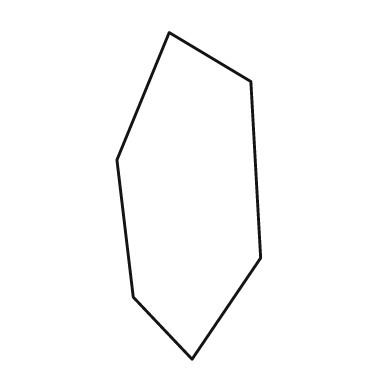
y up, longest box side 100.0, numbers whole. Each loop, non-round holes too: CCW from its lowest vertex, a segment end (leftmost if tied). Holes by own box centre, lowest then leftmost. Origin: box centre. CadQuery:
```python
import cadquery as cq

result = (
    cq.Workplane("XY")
    .moveTo(1.0, -50.0)
    .lineTo(22.0, -19.0)
    .lineTo(19.0, 35.0)
    .lineTo(-6.0, 50.0)
    .lineTo(-22.0, 11.0)
    .lineTo(-17.0, -31.0)
    .close()
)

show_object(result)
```